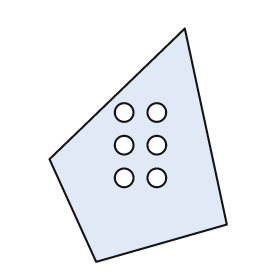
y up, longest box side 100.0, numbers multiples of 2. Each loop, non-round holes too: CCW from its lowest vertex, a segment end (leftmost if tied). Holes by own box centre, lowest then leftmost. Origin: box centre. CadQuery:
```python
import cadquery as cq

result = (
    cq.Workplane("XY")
    .moveTo(-18.0, -50.0)
    .lineTo(38.0, -34.0)
    .lineTo(20.0, 50.0)
    .lineTo(-38.0, -6.0)
    .close()
    .moveTo(-6.0, -14.0)
    .circle(4.0)
    .moveTo(8.0, -14.0)
    .circle(4.0)
    .moveTo(-6.0, 0.0)
    .circle(4.0)
    .moveTo(8.0, 0.0)
    .circle(4.0)
    .moveTo(-6.0, 14.0)
    .circle(4.0)
    .moveTo(8.0, 14.0)
    .circle(4.0)
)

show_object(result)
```